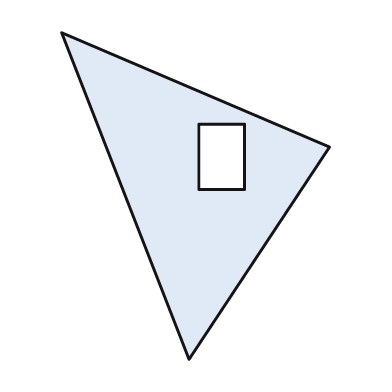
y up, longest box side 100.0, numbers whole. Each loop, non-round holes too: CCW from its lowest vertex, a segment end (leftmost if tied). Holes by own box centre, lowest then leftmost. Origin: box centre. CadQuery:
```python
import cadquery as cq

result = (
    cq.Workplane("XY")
    .moveTo(-2.0, -50.0)
    .lineTo(41.0, 15.0)
    .lineTo(-41.0, 50.0)
    .close()
    .moveTo(1.0, 2.0)
    .lineTo(15.0, 2.0)
    .lineTo(15.0, 22.0)
    .lineTo(1.0, 22.0)
    .close()
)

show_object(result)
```